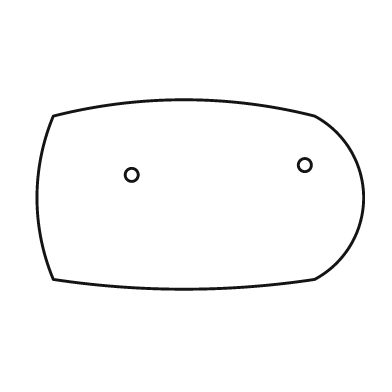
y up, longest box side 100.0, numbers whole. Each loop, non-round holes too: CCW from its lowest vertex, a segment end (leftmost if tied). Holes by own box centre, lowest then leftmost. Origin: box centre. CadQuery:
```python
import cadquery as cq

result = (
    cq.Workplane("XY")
    .moveTo(-45.0, -26.0)
    .threePointArc((-5.0, -29.0), (35.0, -26.0))
    .threePointArc((50.0, -1.0), (35.0, 24.0))
    .threePointArc((-5.0, 29.0), (-45.0, 24.0))
    .threePointArc((-50.0, -1.0), (-45.0, -26.0))
    .close()
    .moveTo(-21.0, 6.0)
    .circle(2.0)
    .moveTo(32.0, 9.0)
    .circle(2.0)
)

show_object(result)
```